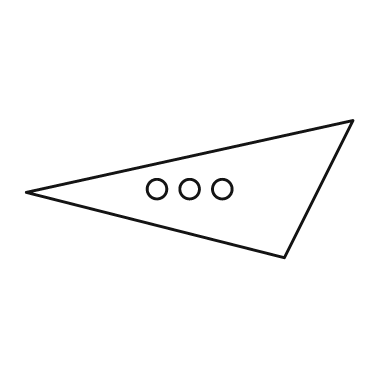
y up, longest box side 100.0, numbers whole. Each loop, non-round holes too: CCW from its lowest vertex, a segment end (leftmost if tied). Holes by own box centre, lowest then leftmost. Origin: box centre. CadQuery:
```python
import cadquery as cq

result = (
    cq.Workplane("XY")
    .moveTo(29.0, -21.0)
    .lineTo(50.0, 21.0)
    .lineTo(-50.0, -1.0)
    .close()
    .moveTo(-10.0, 0.0)
    .circle(3.0)
    .moveTo(0.0, 0.0)
    .circle(3.0)
    .moveTo(10.0, 0.0)
    .circle(3.0)
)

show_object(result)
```